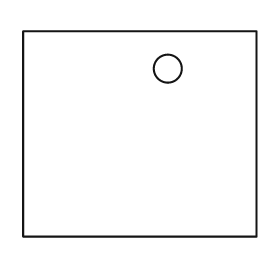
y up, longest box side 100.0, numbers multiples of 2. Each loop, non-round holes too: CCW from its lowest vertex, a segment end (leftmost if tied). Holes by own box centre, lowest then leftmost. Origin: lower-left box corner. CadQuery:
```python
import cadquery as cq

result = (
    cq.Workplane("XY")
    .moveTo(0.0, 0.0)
    .lineTo(100.0, 0.0)
    .lineTo(100.0, 88.0)
    .lineTo(0.0, 88.0)
    .close()
    .moveTo(62.0, 72.0)
    .circle(6.0)
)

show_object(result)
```